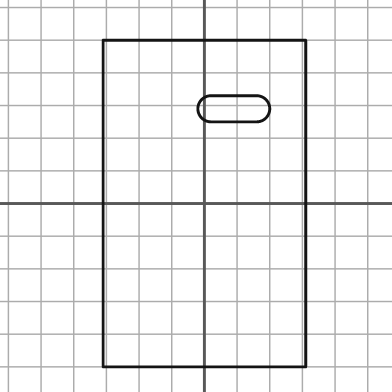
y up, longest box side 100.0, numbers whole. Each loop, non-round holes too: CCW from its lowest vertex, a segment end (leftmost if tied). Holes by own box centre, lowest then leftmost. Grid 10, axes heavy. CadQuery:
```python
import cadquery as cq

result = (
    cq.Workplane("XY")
    .moveTo(-31.0, -50.0)
    .lineTo(31.0, -50.0)
    .lineTo(31.0, 50.0)
    .lineTo(-31.0, 50.0)
    .close()
    .moveTo(2.0, 25.0)
    .lineTo(16.0, 25.0)
    .threePointArc((20.0, 29.0), (16.0, 33.0))
    .lineTo(2.0, 33.0)
    .threePointArc((-2.0, 29.0), (2.0, 25.0))
    .close()
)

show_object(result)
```